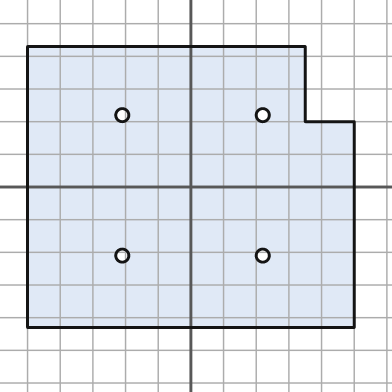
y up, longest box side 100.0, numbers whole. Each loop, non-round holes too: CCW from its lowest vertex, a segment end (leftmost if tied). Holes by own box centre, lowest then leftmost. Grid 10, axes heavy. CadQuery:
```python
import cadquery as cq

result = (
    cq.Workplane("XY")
    .moveTo(-50.0, -43.0)
    .lineTo(50.0, -43.0)
    .lineTo(50.0, 20.0)
    .lineTo(35.0, 20.0)
    .lineTo(35.0, 43.0)
    .lineTo(-50.0, 43.0)
    .close()
    .moveTo(-21.0, -21.0)
    .circle(2.0)
    .moveTo(22.0, -21.0)
    .circle(2.0)
    .moveTo(-21.0, 22.0)
    .circle(2.0)
    .moveTo(22.0, 22.0)
    .circle(2.0)
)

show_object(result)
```